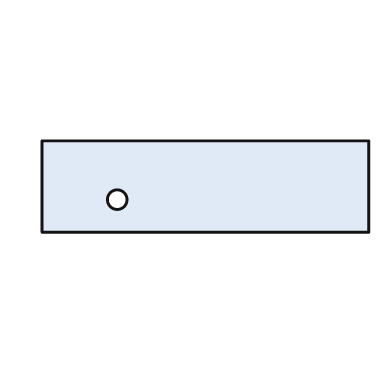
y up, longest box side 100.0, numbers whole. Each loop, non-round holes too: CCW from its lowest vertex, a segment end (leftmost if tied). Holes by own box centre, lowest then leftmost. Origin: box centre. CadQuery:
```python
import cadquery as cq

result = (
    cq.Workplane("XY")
    .moveTo(-50.0, -14.0)
    .lineTo(50.0, -14.0)
    .lineTo(50.0, 14.0)
    .lineTo(-50.0, 14.0)
    .close()
    .moveTo(-27.0, -4.0)
    .circle(3.0)
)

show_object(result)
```